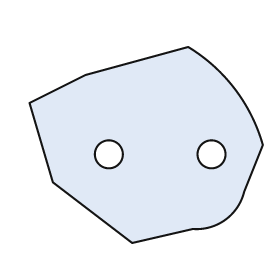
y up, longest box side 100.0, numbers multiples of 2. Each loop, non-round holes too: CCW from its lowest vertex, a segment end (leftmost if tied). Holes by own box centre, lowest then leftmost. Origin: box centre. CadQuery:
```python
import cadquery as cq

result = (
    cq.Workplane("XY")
    .moveTo(-6.0, -42.0)
    .lineTo(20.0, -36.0)
    .threePointArc((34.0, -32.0), (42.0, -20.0))
    .lineTo(50.0, 0.0)
    .threePointArc((38.0, 24.0), (18.0, 42.0))
    .lineTo(-26.0, 30.0)
    .lineTo(-50.0, 18.0)
    .lineTo(-40.0, -16.0)
    .close()
    .moveTo(-16.0, -4.0)
    .circle(6.0)
    .moveTo(28.0, -4.0)
    .circle(6.0)
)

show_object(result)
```